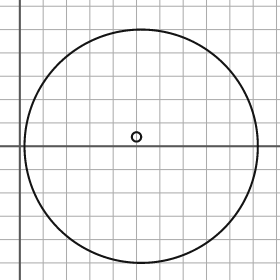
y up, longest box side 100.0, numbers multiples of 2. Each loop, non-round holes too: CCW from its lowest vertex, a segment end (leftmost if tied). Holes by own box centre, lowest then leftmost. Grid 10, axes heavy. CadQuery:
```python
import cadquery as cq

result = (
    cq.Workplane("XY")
    .moveTo(52.0, 0.0)
    .circle(50.0)
    .moveTo(50.0, 4.0)
    .circle(2.0)
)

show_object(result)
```